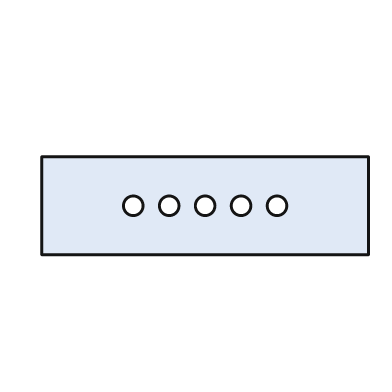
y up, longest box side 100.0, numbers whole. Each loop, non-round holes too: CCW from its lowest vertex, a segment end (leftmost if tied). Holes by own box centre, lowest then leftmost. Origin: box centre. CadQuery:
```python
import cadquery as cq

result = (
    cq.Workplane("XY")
    .moveTo(-50.0, -15.0)
    .lineTo(50.0, -15.0)
    .lineTo(50.0, 15.0)
    .lineTo(-50.0, 15.0)
    .close()
    .moveTo(-22.0, 0.0)
    .circle(3.0)
    .moveTo(-11.0, 0.0)
    .circle(3.0)
    .moveTo(0.0, 0.0)
    .circle(3.0)
    .moveTo(11.0, 0.0)
    .circle(3.0)
    .moveTo(22.0, 0.0)
    .circle(3.0)
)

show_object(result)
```